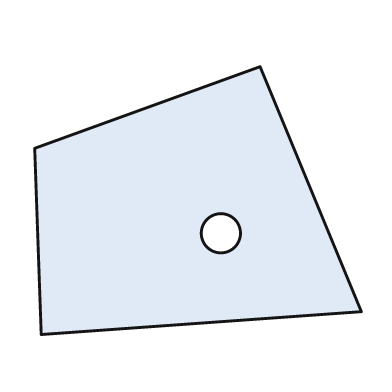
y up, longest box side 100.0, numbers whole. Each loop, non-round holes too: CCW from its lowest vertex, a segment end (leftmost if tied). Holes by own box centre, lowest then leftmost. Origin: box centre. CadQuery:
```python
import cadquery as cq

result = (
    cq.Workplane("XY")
    .moveTo(-48.0, -41.0)
    .lineTo(50.0, -34.0)
    .lineTo(19.0, 41.0)
    .lineTo(-50.0, 16.0)
    .close()
    .moveTo(7.0, -10.0)
    .circle(6.0)
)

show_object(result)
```